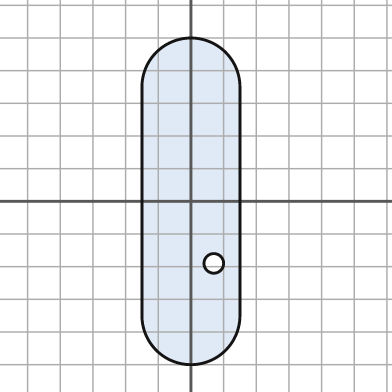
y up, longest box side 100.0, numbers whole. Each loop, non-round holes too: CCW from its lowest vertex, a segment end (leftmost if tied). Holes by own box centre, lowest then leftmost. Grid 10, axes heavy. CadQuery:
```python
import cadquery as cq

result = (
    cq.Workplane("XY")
    .moveTo(-15.0, -35.0)
    .threePointArc((0.0, -50.0), (15.0, -35.0))
    .lineTo(15.0, 35.0)
    .threePointArc((0.0, 50.0), (-15.0, 35.0))
    .close()
    .moveTo(7.0, -19.0)
    .circle(3.0)
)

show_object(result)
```